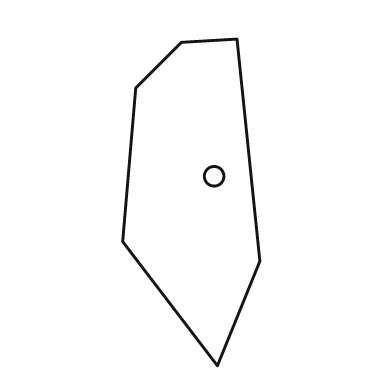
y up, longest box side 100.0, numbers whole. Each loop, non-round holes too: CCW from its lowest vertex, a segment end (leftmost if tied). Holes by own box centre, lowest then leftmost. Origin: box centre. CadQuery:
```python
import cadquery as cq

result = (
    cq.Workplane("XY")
    .moveTo(8.0, -50.0)
    .lineTo(21.0, -18.0)
    .lineTo(14.0, 50.0)
    .lineTo(-3.0, 49.0)
    .lineTo(-17.0, 35.0)
    .lineTo(-21.0, -12.0)
    .close()
    .moveTo(7.0, 8.0)
    .circle(3.0)
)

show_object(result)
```